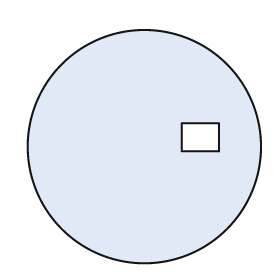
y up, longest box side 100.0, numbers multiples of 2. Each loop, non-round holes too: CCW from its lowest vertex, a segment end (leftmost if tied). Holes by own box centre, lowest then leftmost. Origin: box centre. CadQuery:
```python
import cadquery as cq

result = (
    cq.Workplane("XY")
    .moveTo(0.0, 0.0)
    .circle(50.0)
    .moveTo(16.0, -2.0)
    .lineTo(32.0, -2.0)
    .lineTo(32.0, 10.0)
    .lineTo(16.0, 10.0)
    .close()
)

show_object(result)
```